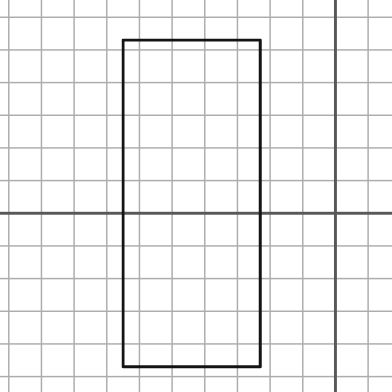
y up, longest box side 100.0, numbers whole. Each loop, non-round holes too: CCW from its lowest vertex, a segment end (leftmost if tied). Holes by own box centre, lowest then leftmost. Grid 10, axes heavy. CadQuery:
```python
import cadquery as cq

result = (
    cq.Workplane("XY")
    .moveTo(-65.0, -47.0)
    .lineTo(-23.0, -47.0)
    .lineTo(-23.0, 53.0)
    .lineTo(-65.0, 53.0)
    .close()
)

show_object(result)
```